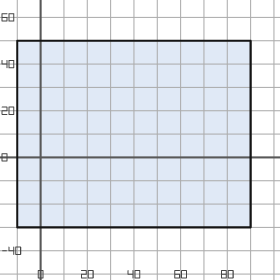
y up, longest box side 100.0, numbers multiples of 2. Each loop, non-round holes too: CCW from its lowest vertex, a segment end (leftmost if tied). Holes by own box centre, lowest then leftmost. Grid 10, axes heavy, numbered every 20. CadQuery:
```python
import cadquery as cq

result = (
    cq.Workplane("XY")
    .moveTo(-10.0, -30.0)
    .lineTo(90.0, -30.0)
    .lineTo(90.0, 50.0)
    .lineTo(-10.0, 50.0)
    .close()
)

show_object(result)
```